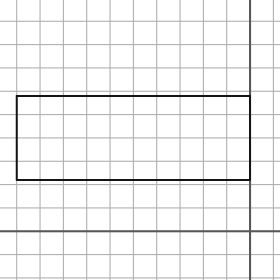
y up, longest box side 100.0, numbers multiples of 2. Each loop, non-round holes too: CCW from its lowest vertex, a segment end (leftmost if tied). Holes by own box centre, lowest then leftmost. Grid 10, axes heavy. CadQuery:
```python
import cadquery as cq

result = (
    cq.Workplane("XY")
    .moveTo(-100.0, 22.0)
    .lineTo(0.0, 22.0)
    .lineTo(0.0, 58.0)
    .lineTo(-100.0, 58.0)
    .close()
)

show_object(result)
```